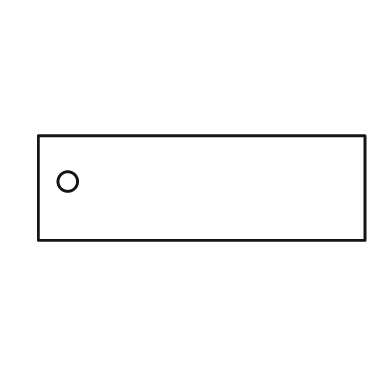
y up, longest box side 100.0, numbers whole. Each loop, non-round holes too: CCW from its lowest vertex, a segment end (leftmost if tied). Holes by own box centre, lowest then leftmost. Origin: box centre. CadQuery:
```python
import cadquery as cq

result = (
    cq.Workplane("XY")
    .moveTo(-50.0, -16.0)
    .lineTo(50.0, -16.0)
    .lineTo(50.0, 16.0)
    .lineTo(-50.0, 16.0)
    .close()
    .moveTo(-41.0, 2.0)
    .circle(3.0)
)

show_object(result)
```